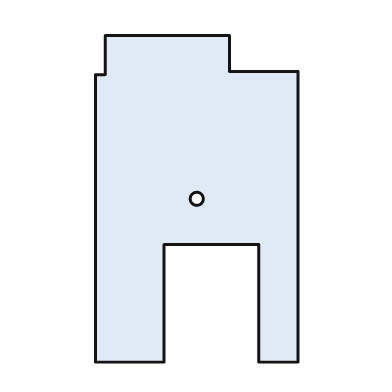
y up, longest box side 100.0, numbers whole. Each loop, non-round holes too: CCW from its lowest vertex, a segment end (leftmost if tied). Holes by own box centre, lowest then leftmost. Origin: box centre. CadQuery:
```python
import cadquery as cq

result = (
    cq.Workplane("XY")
    .moveTo(-31.0, -50.0)
    .lineTo(-10.0, -50.0)
    .lineTo(-10.0, -14.0)
    .lineTo(19.0, -14.0)
    .lineTo(19.0, -50.0)
    .lineTo(31.0, -50.0)
    .lineTo(31.0, 39.0)
    .lineTo(10.0, 39.0)
    .lineTo(10.0, 50.0)
    .lineTo(-28.0, 50.0)
    .lineTo(-28.0, 38.0)
    .lineTo(-31.0, 38.0)
    .close()
    .moveTo(0.0, 0.0)
    .circle(2.0)
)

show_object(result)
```